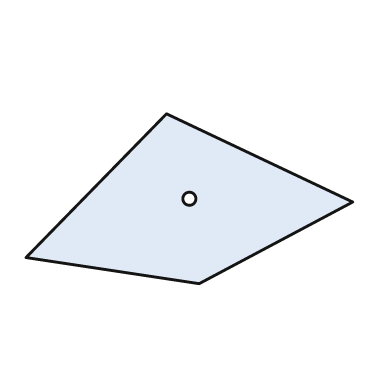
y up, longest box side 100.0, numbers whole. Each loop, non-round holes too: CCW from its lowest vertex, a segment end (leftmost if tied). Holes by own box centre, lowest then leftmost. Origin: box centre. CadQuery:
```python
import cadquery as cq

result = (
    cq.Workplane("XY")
    .moveTo(3.0, -26.0)
    .lineTo(50.0, -1.0)
    .lineTo(-7.0, 26.0)
    .lineTo(-50.0, -18.0)
    .close()
    .moveTo(0.0, 0.0)
    .circle(2.0)
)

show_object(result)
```